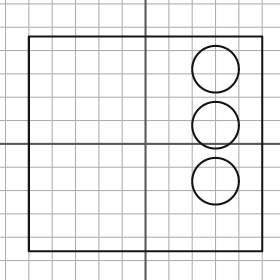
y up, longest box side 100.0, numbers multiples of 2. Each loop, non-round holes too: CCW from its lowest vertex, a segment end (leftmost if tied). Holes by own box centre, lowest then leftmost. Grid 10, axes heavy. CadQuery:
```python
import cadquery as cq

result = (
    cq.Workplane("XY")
    .moveTo(-50.0, -46.0)
    .lineTo(50.0, -46.0)
    .lineTo(50.0, 46.0)
    .lineTo(-50.0, 46.0)
    .close()
    .moveTo(30.0, -16.0)
    .circle(10.0)
    .moveTo(30.0, 8.0)
    .circle(10.0)
    .moveTo(30.0, 32.0)
    .circle(10.0)
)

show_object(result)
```